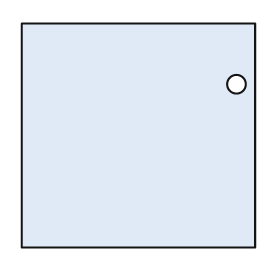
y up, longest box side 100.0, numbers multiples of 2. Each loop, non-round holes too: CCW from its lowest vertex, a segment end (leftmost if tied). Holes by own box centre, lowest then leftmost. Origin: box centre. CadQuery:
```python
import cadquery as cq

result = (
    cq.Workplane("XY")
    .moveTo(-50.0, -48.0)
    .lineTo(50.0, -48.0)
    .lineTo(50.0, 48.0)
    .lineTo(-50.0, 48.0)
    .close()
    .moveTo(42.0, 22.0)
    .circle(4.0)
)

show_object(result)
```